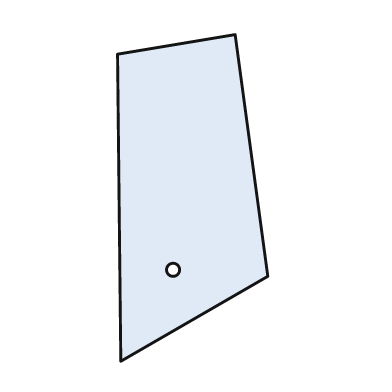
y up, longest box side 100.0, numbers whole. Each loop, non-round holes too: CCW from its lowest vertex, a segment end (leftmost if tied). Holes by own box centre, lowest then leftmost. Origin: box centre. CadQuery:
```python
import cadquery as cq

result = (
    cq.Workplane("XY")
    .moveTo(-22.0, -50.0)
    .lineTo(23.0, -24.0)
    .lineTo(13.0, 50.0)
    .lineTo(-23.0, 44.0)
    .close()
    .moveTo(-6.0, -22.0)
    .circle(2.0)
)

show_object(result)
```